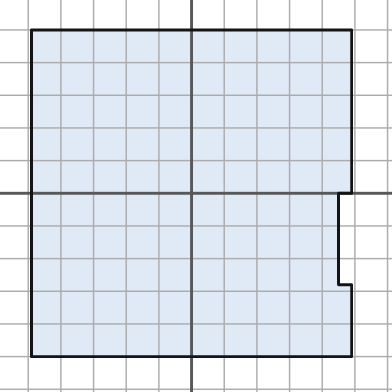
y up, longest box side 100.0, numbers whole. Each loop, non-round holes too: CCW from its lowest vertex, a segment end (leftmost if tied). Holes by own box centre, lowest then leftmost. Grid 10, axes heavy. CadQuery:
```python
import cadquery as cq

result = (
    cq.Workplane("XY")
    .moveTo(-49.0, -50.0)
    .lineTo(49.0, -50.0)
    .lineTo(49.0, -28.0)
    .lineTo(45.0, -28.0)
    .lineTo(45.0, 0.0)
    .lineTo(49.0, 0.0)
    .lineTo(49.0, 50.0)
    .lineTo(-49.0, 50.0)
    .close()
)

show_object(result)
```